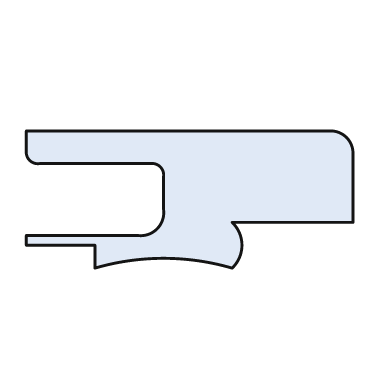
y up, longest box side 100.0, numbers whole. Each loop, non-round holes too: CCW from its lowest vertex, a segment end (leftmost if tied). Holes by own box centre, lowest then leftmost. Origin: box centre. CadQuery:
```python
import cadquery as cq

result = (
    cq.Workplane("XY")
    .moveTo(-29.0, -21.0)
    .threePointArc((-8.0, -18.0), (13.0, -21.0))
    .threePointArc((16.0, -14.0), (13.0, -7.0))
    .lineTo(50.0, -7.0)
    .lineTo(50.0, 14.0)
    .threePointArc((48.0, 19.0), (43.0, 21.0))
    .lineTo(-50.0, 21.0)
    .lineTo(-50.0, 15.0)
    .threePointArc((-49.0, 12.0), (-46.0, 11.0))
    .lineTo(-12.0, 11.0)
    .threePointArc((-9.0, 10.0), (-8.0, 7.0))
    .lineTo(-8.0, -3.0)
    .threePointArc((-10.0, -9.0), (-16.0, -11.0))
    .lineTo(-50.0, -11.0)
    .lineTo(-50.0, -14.0)
    .lineTo(-29.0, -14.0)
    .close()
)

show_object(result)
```